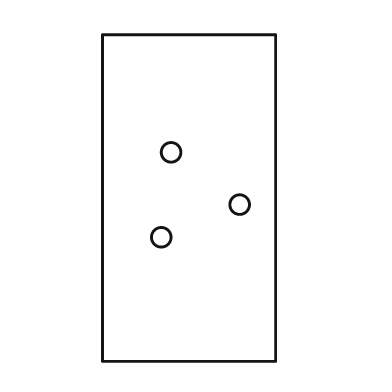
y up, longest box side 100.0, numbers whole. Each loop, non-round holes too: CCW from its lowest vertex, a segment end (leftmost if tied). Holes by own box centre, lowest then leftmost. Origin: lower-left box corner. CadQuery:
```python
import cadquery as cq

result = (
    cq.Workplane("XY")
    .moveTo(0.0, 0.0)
    .lineTo(53.0, 0.0)
    .lineTo(53.0, 100.0)
    .lineTo(0.0, 100.0)
    .close()
    .moveTo(18.0, 38.0)
    .circle(3.0)
    .moveTo(42.0, 48.0)
    .circle(3.0)
    .moveTo(21.0, 64.0)
    .circle(3.0)
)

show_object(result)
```